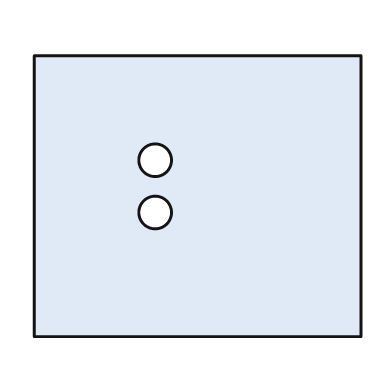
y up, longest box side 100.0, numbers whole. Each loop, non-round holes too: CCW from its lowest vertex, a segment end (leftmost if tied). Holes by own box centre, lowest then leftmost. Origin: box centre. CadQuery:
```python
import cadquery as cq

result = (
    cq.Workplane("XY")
    .moveTo(-50.0, -43.0)
    .lineTo(50.0, -43.0)
    .lineTo(50.0, 43.0)
    .lineTo(-50.0, 43.0)
    .close()
    .moveTo(-13.0, -5.0)
    .circle(5.0)
    .moveTo(-13.0, 11.0)
    .circle(5.0)
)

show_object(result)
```